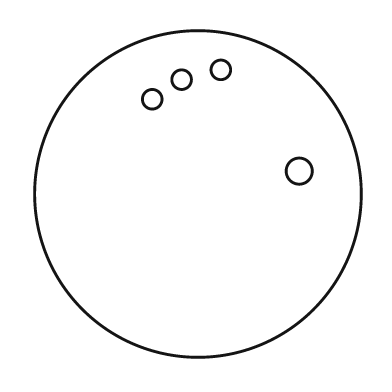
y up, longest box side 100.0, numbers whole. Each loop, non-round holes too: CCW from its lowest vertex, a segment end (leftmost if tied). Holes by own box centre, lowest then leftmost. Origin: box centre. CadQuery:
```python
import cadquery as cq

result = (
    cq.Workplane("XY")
    .moveTo(0.0, 0.0)
    .circle(50.0)
    .moveTo(31.0, 7.0)
    .circle(4.0)
    .moveTo(-14.0, 29.0)
    .circle(3.0)
    .moveTo(-5.0, 35.0)
    .circle(3.0)
    .moveTo(7.0, 38.0)
    .circle(3.0)
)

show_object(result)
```